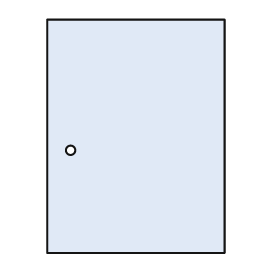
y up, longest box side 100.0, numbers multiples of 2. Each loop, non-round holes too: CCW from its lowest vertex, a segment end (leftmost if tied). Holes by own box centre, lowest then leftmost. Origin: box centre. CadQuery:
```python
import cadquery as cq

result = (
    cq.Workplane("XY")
    .moveTo(-38.0, -50.0)
    .lineTo(38.0, -50.0)
    .lineTo(38.0, 50.0)
    .lineTo(-38.0, 50.0)
    .close()
    .moveTo(-28.0, -6.0)
    .circle(2.0)
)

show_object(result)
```